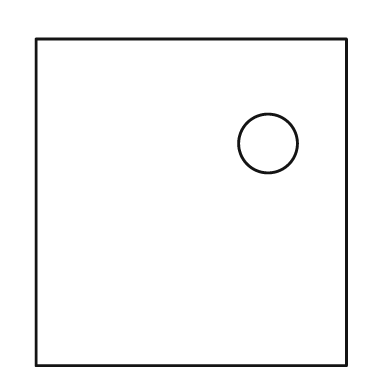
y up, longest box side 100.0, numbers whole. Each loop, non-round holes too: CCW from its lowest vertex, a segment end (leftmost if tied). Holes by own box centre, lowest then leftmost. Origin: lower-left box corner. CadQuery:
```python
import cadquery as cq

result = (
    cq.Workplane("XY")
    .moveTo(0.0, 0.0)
    .lineTo(95.0, 0.0)
    .lineTo(95.0, 100.0)
    .lineTo(0.0, 100.0)
    .close()
    .moveTo(71.0, 68.0)
    .circle(9.0)
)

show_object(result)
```